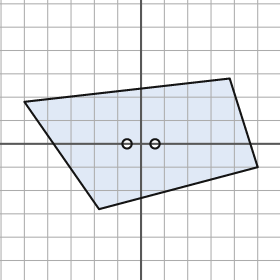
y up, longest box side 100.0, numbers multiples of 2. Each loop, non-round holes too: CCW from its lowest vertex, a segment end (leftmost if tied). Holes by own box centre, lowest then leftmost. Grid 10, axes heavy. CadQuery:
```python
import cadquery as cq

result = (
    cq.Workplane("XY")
    .moveTo(-18.0, -28.0)
    .lineTo(50.0, -10.0)
    .lineTo(38.0, 28.0)
    .lineTo(-50.0, 18.0)
    .close()
    .moveTo(-6.0, 0.0)
    .circle(2.0)
    .moveTo(6.0, 0.0)
    .circle(2.0)
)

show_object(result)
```